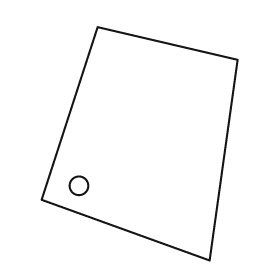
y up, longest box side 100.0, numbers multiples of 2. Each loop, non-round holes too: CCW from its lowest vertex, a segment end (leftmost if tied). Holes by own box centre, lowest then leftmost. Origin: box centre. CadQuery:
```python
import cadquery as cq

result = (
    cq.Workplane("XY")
    .moveTo(30.0, -50.0)
    .lineTo(42.0, 36.0)
    .lineTo(-18.0, 50.0)
    .lineTo(-42.0, -24.0)
    .close()
    .moveTo(-26.0, -18.0)
    .circle(4.0)
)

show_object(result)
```